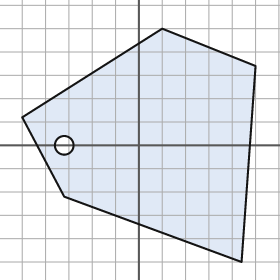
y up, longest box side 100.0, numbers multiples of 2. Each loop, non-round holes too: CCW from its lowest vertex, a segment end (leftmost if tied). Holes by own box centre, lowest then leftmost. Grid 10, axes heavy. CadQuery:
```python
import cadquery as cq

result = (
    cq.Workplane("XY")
    .moveTo(44.0, -50.0)
    .lineTo(50.0, 34.0)
    .lineTo(10.0, 50.0)
    .lineTo(-50.0, 12.0)
    .lineTo(-32.0, -22.0)
    .close()
    .moveTo(-32.0, 0.0)
    .circle(4.0)
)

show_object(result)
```